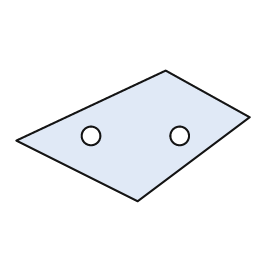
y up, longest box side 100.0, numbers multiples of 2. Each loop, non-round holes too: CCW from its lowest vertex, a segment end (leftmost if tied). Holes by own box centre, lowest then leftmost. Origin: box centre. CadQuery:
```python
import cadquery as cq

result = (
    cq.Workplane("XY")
    .moveTo(2.0, -28.0)
    .lineTo(50.0, 8.0)
    .lineTo(14.0, 28.0)
    .lineTo(-50.0, -2.0)
    .close()
    .moveTo(-18.0, 0.0)
    .circle(4.0)
    .moveTo(20.0, 0.0)
    .circle(4.0)
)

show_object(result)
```